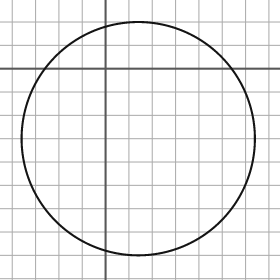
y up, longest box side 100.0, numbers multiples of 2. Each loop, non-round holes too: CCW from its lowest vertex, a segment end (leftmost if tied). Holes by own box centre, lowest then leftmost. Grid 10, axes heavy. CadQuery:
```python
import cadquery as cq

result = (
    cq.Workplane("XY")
    .moveTo(14.0, -30.0)
    .circle(50.0)
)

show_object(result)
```